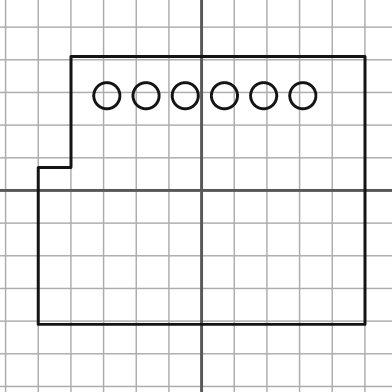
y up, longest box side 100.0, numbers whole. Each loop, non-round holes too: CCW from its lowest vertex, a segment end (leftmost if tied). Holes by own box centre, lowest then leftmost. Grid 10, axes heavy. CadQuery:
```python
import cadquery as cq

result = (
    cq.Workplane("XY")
    .moveTo(-50.0, -41.0)
    .lineTo(50.0, -41.0)
    .lineTo(50.0, 41.0)
    .lineTo(-40.0, 41.0)
    .lineTo(-40.0, 7.0)
    .lineTo(-50.0, 7.0)
    .close()
    .moveTo(-29.0, 29.0)
    .circle(4.0)
    .moveTo(-17.0, 29.0)
    .circle(4.0)
    .moveTo(-5.0, 29.0)
    .circle(4.0)
    .moveTo(7.0, 29.0)
    .circle(4.0)
    .moveTo(19.0, 29.0)
    .circle(4.0)
    .moveTo(31.0, 29.0)
    .circle(4.0)
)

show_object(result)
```